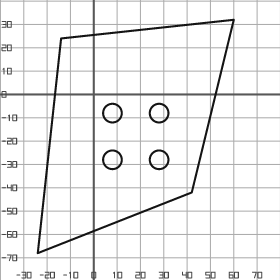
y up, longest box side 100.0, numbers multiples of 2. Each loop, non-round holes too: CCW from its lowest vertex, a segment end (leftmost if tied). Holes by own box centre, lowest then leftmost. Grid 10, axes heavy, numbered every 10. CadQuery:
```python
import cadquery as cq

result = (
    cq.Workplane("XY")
    .moveTo(-24.0, -68.0)
    .lineTo(42.0, -42.0)
    .lineTo(60.0, 32.0)
    .lineTo(-14.0, 24.0)
    .close()
    .moveTo(8.0, -28.0)
    .circle(4.0)
    .moveTo(28.0, -28.0)
    .circle(4.0)
    .moveTo(8.0, -8.0)
    .circle(4.0)
    .moveTo(28.0, -8.0)
    .circle(4.0)
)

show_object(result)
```